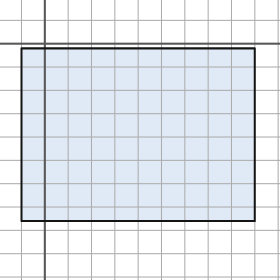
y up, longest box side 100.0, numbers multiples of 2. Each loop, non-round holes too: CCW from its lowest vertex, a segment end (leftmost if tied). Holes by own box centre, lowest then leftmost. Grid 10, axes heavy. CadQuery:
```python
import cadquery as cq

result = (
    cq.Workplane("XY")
    .moveTo(-10.0, -76.0)
    .lineTo(90.0, -76.0)
    .lineTo(90.0, -2.0)
    .lineTo(-10.0, -2.0)
    .close()
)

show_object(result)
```